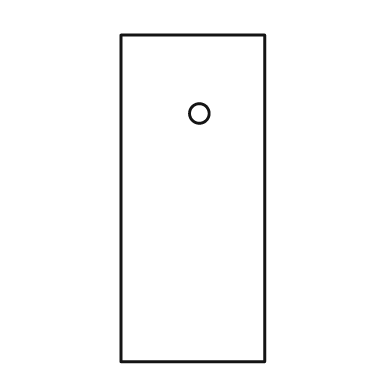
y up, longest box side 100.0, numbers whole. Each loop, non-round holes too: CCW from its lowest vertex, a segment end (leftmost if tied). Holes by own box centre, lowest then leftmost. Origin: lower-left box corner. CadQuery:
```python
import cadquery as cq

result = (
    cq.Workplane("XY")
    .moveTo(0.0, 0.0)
    .lineTo(44.0, 0.0)
    .lineTo(44.0, 100.0)
    .lineTo(0.0, 100.0)
    .close()
    .moveTo(24.0, 76.0)
    .circle(3.0)
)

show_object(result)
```